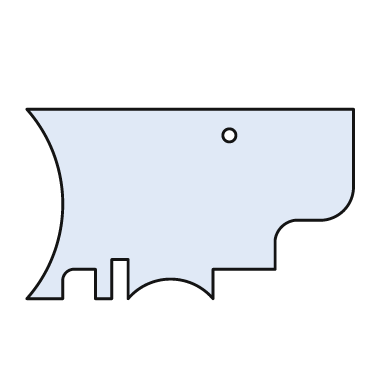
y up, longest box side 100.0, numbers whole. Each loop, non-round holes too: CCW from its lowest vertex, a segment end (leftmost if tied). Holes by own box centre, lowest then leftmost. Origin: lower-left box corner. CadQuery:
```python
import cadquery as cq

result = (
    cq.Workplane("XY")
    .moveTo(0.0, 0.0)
    .lineTo(11.0, 0.0)
    .lineTo(11.0, 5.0)
    .threePointArc((12.0, 8.0), (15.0, 9.0))
    .lineTo(21.0, 9.0)
    .lineTo(21.0, 0.0)
    .lineTo(26.0, 0.0)
    .lineTo(26.0, 12.0)
    .lineTo(31.0, 12.0)
    .lineTo(31.0, 0.0)
    .threePointArc((44.0, 6.0), (57.0, 0.0))
    .lineTo(57.0, 9.0)
    .lineTo(76.0, 9.0)
    .lineTo(76.0, 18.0)
    .threePointArc((78.0, 22.0), (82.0, 24.0))
    .lineTo(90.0, 24.0)
    .threePointArc((97.0, 27.0), (100.0, 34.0))
    .lineTo(100.0, 58.0)
    .lineTo(0.0, 58.0)
    .threePointArc((11.0, 29.0), (0.0, 0.0))
    .close()
    .moveTo(62.0, 50.0)
    .circle(2.0)
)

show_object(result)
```